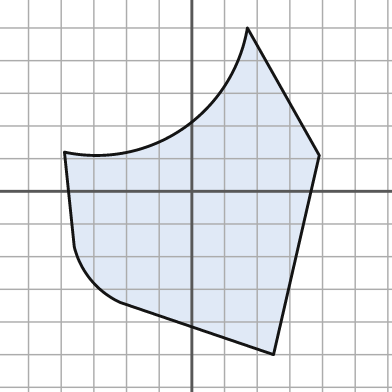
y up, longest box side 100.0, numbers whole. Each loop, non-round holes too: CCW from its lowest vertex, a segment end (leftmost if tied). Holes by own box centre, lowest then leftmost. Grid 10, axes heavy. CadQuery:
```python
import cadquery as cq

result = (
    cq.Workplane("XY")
    .moveTo(25.0, -50.0)
    .lineTo(39.0, 11.0)
    .lineTo(17.0, 50.0)
    .threePointArc((-3.0, 19.0), (-39.0, 12.0))
    .lineTo(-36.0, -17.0)
    .threePointArc((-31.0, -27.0), (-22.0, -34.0))
    .close()
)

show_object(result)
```